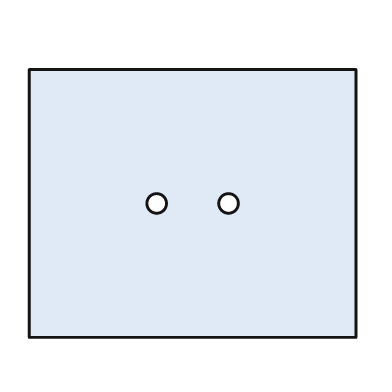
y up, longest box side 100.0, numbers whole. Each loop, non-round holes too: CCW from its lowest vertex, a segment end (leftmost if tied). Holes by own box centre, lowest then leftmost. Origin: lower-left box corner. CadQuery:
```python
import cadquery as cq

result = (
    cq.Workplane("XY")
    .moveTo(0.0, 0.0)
    .lineTo(100.0, 0.0)
    .lineTo(100.0, 82.0)
    .lineTo(0.0, 82.0)
    .close()
    .moveTo(39.0, 41.0)
    .circle(3.0)
    .moveTo(61.0, 41.0)
    .circle(3.0)
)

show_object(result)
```